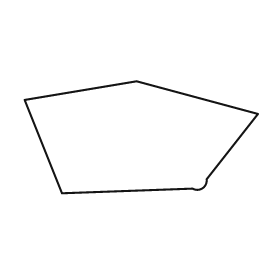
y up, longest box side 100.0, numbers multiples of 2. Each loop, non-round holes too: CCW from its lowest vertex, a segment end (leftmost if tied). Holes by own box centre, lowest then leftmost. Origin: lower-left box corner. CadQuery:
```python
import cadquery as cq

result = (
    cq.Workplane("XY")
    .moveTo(16.0, 0.0)
    .lineTo(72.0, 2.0)
    .threePointArc((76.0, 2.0), (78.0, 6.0))
    .lineTo(100.0, 34.0)
    .lineTo(48.0, 48.0)
    .lineTo(0.0, 40.0)
    .close()
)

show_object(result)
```